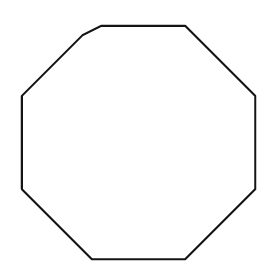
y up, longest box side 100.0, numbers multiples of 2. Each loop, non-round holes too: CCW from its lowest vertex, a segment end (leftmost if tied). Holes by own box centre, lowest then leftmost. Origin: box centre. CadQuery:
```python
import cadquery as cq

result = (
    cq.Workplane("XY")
    .moveTo(-20.0, -50.0)
    .lineTo(20.0, -50.0)
    .lineTo(50.0, -20.0)
    .lineTo(50.0, 20.0)
    .lineTo(20.0, 50.0)
    .lineTo(-16.0, 50.0)
    .lineTo(-24.0, 46.0)
    .lineTo(-50.0, 20.0)
    .lineTo(-50.0, -20.0)
    .close()
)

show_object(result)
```